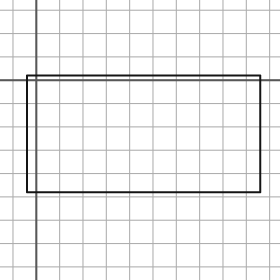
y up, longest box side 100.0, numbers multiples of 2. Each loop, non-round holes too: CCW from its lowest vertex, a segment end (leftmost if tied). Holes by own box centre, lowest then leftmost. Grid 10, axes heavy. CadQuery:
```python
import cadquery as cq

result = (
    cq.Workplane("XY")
    .moveTo(-4.0, -48.0)
    .lineTo(96.0, -48.0)
    .lineTo(96.0, 2.0)
    .lineTo(-4.0, 2.0)
    .close()
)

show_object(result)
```